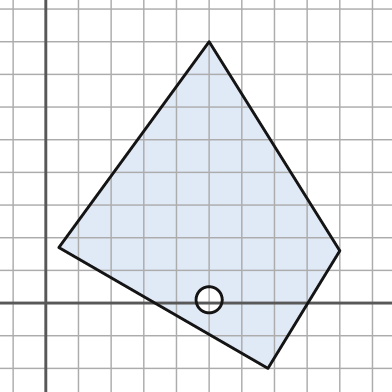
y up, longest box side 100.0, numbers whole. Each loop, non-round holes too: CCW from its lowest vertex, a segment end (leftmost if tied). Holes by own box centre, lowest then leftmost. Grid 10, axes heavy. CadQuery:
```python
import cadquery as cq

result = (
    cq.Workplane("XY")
    .moveTo(68.0, -20.0)
    .lineTo(90.0, 16.0)
    .lineTo(50.0, 80.0)
    .lineTo(4.0, 17.0)
    .close()
    .moveTo(50.0, 1.0)
    .circle(4.0)
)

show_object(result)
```